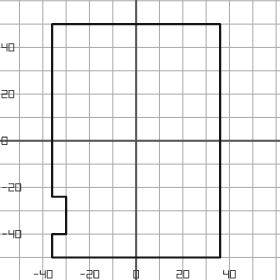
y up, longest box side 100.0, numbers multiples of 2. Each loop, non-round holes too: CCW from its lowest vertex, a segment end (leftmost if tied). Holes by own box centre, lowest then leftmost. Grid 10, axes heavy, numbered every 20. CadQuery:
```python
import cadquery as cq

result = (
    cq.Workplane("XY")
    .moveTo(-36.0, -50.0)
    .lineTo(36.0, -50.0)
    .lineTo(36.0, 50.0)
    .lineTo(-36.0, 50.0)
    .lineTo(-36.0, -24.0)
    .lineTo(-30.0, -24.0)
    .lineTo(-30.0, -40.0)
    .lineTo(-36.0, -40.0)
    .close()
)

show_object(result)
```